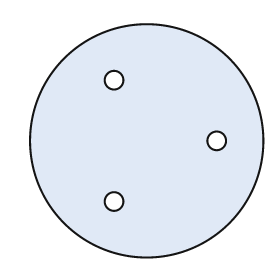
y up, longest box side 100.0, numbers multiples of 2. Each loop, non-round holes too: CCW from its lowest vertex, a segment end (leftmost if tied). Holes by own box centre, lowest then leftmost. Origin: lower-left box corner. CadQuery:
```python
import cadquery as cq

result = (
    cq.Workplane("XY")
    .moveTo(50.0, 50.0)
    .circle(50.0)
    .moveTo(36.0, 24.0)
    .circle(4.0)
    .moveTo(80.0, 50.0)
    .circle(4.0)
    .moveTo(36.0, 76.0)
    .circle(4.0)
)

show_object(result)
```